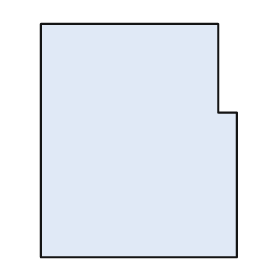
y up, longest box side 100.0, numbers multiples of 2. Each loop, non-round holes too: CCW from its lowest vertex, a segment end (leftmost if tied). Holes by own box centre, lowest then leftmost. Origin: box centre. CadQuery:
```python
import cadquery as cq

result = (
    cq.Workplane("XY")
    .moveTo(-42.0, -50.0)
    .lineTo(42.0, -50.0)
    .lineTo(42.0, 12.0)
    .lineTo(34.0, 12.0)
    .lineTo(34.0, 50.0)
    .lineTo(-42.0, 50.0)
    .close()
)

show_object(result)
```